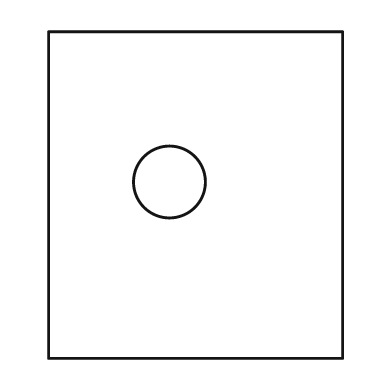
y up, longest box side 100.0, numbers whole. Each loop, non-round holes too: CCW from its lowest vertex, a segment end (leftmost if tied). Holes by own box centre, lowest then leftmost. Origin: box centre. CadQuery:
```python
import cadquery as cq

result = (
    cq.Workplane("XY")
    .moveTo(-45.0, -50.0)
    .lineTo(45.0, -50.0)
    .lineTo(45.0, 50.0)
    .lineTo(-45.0, 50.0)
    .close()
    .moveTo(-8.0, 4.0)
    .circle(11.0)
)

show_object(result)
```